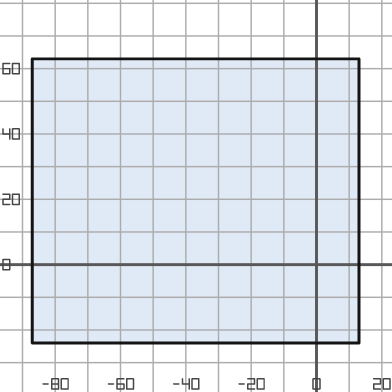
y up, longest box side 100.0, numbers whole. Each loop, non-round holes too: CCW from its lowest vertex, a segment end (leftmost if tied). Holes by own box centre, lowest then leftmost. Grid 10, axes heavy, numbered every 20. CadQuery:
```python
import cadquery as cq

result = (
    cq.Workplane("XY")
    .moveTo(-87.0, -24.0)
    .lineTo(13.0, -24.0)
    .lineTo(13.0, 63.0)
    .lineTo(-87.0, 63.0)
    .close()
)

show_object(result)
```